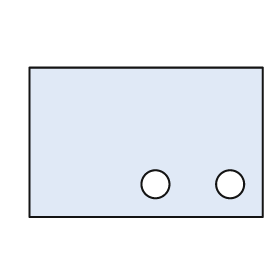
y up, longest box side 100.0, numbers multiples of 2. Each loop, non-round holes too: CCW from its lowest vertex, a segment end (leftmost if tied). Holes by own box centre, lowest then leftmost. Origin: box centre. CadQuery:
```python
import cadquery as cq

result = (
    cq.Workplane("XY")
    .moveTo(-50.0, -32.0)
    .lineTo(50.0, -32.0)
    .lineTo(50.0, 32.0)
    .lineTo(-50.0, 32.0)
    .close()
    .moveTo(4.0, -18.0)
    .circle(6.0)
    .moveTo(36.0, -18.0)
    .circle(6.0)
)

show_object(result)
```